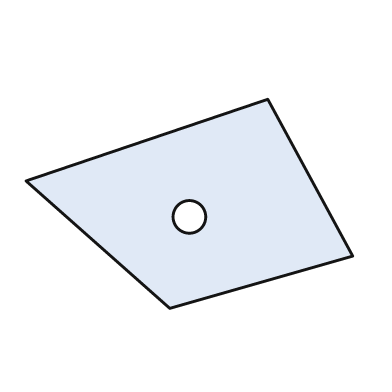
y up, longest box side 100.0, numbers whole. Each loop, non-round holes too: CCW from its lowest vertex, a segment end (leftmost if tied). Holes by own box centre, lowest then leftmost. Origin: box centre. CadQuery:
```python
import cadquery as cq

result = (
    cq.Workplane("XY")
    .moveTo(-6.0, -32.0)
    .lineTo(50.0, -16.0)
    .lineTo(24.0, 32.0)
    .lineTo(-50.0, 7.0)
    .close()
    .moveTo(0.0, -4.0)
    .circle(5.0)
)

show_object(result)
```